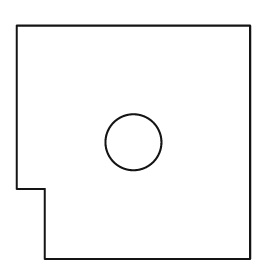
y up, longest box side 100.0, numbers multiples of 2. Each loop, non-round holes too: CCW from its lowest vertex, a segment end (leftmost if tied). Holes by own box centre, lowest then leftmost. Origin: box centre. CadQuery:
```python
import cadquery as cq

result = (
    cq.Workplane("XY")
    .moveTo(-38.0, -50.0)
    .lineTo(50.0, -50.0)
    .lineTo(50.0, 50.0)
    .lineTo(-50.0, 50.0)
    .lineTo(-50.0, -20.0)
    .lineTo(-38.0, -20.0)
    .close()
    .moveTo(0.0, 0.0)
    .circle(12.0)
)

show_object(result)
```